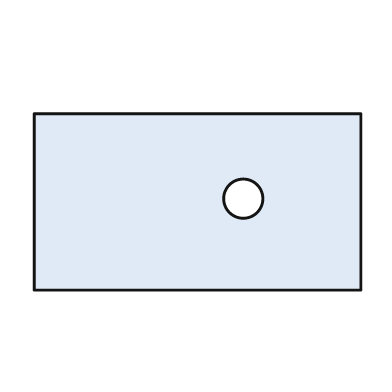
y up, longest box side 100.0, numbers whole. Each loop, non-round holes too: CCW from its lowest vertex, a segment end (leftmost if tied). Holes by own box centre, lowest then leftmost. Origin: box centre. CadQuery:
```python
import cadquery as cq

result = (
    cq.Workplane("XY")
    .moveTo(-50.0, -27.0)
    .lineTo(50.0, -27.0)
    .lineTo(50.0, 27.0)
    .lineTo(-50.0, 27.0)
    .close()
    .moveTo(14.0, 1.0)
    .circle(6.0)
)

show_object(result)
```